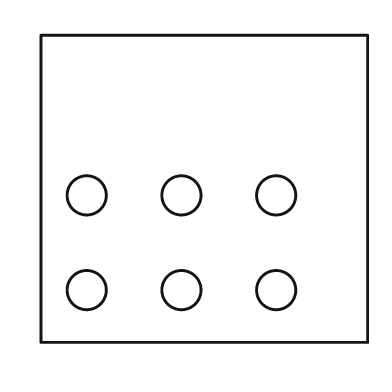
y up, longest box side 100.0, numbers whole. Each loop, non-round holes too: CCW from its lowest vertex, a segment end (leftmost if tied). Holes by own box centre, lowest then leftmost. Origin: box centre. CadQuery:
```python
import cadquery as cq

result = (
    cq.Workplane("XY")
    .moveTo(-50.0, -47.0)
    .lineTo(50.0, -47.0)
    .lineTo(50.0, 47.0)
    .lineTo(-50.0, 47.0)
    .close()
    .moveTo(-36.0, -31.0)
    .circle(6.0)
    .moveTo(-7.0, -31.0)
    .circle(6.0)
    .moveTo(22.0, -31.0)
    .circle(6.0)
    .moveTo(-36.0, -2.0)
    .circle(6.0)
    .moveTo(-7.0, -2.0)
    .circle(6.0)
    .moveTo(22.0, -2.0)
    .circle(6.0)
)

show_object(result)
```